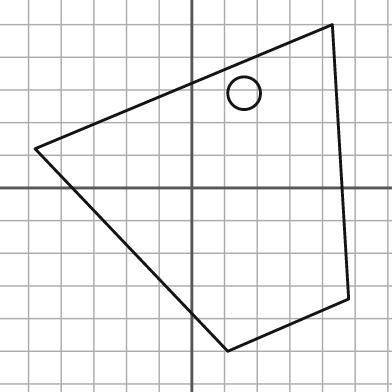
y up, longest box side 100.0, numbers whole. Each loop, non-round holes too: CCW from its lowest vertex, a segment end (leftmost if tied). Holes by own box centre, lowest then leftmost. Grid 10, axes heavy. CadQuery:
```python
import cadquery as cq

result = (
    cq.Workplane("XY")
    .moveTo(11.0, -50.0)
    .lineTo(48.0, -34.0)
    .lineTo(43.0, 50.0)
    .lineTo(-48.0, 12.0)
    .close()
    .moveTo(16.0, 29.0)
    .circle(5.0)
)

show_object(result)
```